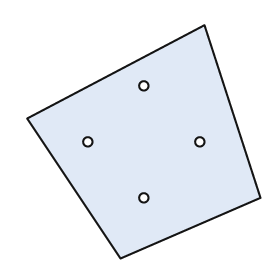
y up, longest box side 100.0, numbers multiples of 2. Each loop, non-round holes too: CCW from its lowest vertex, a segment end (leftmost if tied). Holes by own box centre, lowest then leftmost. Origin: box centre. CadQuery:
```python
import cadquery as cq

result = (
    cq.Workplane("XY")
    .moveTo(-10.0, -50.0)
    .lineTo(50.0, -24.0)
    .lineTo(26.0, 50.0)
    .lineTo(-50.0, 10.0)
    .close()
    .moveTo(0.0, -24.0)
    .circle(2.0)
    .moveTo(-24.0, 0.0)
    .circle(2.0)
    .moveTo(24.0, 0.0)
    .circle(2.0)
    .moveTo(0.0, 24.0)
    .circle(2.0)
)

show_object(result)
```